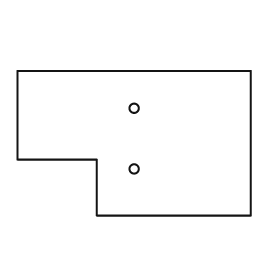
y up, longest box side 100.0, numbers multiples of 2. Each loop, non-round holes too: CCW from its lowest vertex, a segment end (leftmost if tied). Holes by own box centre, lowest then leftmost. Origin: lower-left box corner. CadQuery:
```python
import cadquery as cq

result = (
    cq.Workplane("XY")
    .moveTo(34.0, 0.0)
    .lineTo(100.0, 0.0)
    .lineTo(100.0, 62.0)
    .lineTo(0.0, 62.0)
    .lineTo(0.0, 24.0)
    .lineTo(34.0, 24.0)
    .close()
    .moveTo(50.0, 20.0)
    .circle(2.0)
    .moveTo(50.0, 46.0)
    .circle(2.0)
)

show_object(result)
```